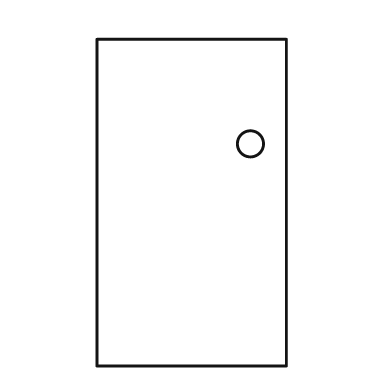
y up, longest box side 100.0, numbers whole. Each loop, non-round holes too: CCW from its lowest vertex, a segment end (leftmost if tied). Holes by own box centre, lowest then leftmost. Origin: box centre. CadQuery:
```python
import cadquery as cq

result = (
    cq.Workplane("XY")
    .moveTo(-29.0, -50.0)
    .lineTo(29.0, -50.0)
    .lineTo(29.0, 50.0)
    .lineTo(-29.0, 50.0)
    .close()
    .moveTo(18.0, 18.0)
    .circle(4.0)
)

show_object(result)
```